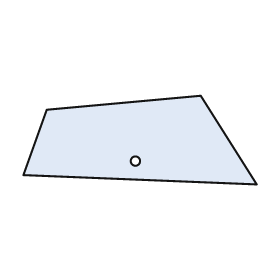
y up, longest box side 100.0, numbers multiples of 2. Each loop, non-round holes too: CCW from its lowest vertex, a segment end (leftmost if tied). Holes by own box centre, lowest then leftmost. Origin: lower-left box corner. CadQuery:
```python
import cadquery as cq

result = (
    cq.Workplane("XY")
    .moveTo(100.0, 0.0)
    .lineTo(76.0, 38.0)
    .lineTo(10.0, 32.0)
    .lineTo(0.0, 4.0)
    .close()
    .moveTo(48.0, 10.0)
    .circle(2.0)
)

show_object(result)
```